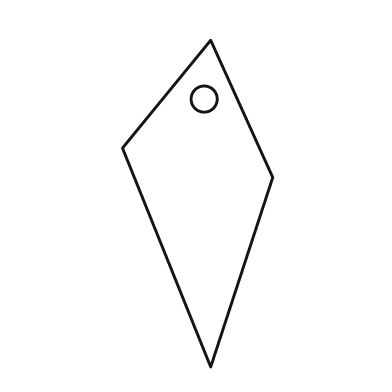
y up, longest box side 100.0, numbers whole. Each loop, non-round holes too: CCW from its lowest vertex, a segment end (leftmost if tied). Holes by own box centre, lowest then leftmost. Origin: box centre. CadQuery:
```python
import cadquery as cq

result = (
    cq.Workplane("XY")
    .moveTo(4.0, -50.0)
    .lineTo(23.0, 8.0)
    .lineTo(4.0, 50.0)
    .lineTo(-23.0, 17.0)
    .close()
    .moveTo(2.0, 32.0)
    .circle(4.0)
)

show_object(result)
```